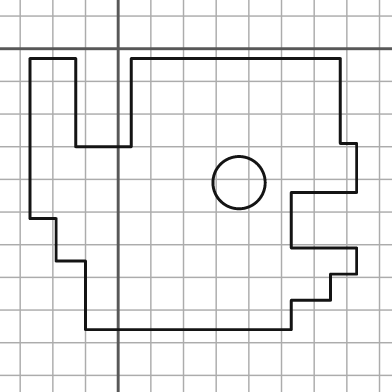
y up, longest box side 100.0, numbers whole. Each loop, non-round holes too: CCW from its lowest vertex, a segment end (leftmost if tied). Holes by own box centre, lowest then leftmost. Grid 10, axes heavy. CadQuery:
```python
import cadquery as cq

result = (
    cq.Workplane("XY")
    .moveTo(-10.0, -86.0)
    .lineTo(53.0, -86.0)
    .lineTo(53.0, -77.0)
    .lineTo(65.0, -77.0)
    .lineTo(65.0, -69.0)
    .lineTo(73.0, -69.0)
    .lineTo(73.0, -61.0)
    .lineTo(53.0, -61.0)
    .lineTo(53.0, -44.0)
    .lineTo(73.0, -44.0)
    .lineTo(73.0, -29.0)
    .lineTo(68.0, -29.0)
    .lineTo(68.0, -3.0)
    .lineTo(4.0, -3.0)
    .lineTo(4.0, -30.0)
    .lineTo(-13.0, -30.0)
    .lineTo(-13.0, -3.0)
    .lineTo(-27.0, -3.0)
    .lineTo(-27.0, -52.0)
    .lineTo(-19.0, -52.0)
    .lineTo(-19.0, -65.0)
    .lineTo(-10.0, -65.0)
    .close()
    .moveTo(37.0, -41.0)
    .circle(8.0)
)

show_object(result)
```